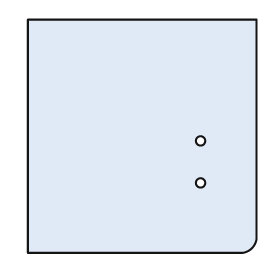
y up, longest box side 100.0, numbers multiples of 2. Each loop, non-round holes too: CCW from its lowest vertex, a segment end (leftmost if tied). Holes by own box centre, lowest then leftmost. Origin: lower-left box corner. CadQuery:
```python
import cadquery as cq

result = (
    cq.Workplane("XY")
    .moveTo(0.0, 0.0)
    .lineTo(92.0, 0.0)
    .threePointArc((96.0, 2.0), (98.0, 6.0))
    .lineTo(98.0, 100.0)
    .lineTo(0.0, 100.0)
    .close()
    .moveTo(74.0, 30.0)
    .circle(2.0)
    .moveTo(74.0, 48.0)
    .circle(2.0)
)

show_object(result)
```